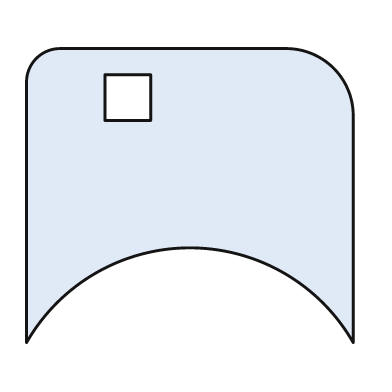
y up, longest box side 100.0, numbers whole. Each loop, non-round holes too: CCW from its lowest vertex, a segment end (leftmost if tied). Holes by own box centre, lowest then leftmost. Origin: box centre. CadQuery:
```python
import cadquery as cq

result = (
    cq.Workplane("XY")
    .moveTo(-50.0, -45.0)
    .threePointArc((0.0, -16.0), (50.0, -45.0))
    .lineTo(50.0, 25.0)
    .threePointArc((44.0, 39.0), (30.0, 45.0))
    .lineTo(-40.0, 45.0)
    .threePointArc((-47.0, 42.0), (-50.0, 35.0))
    .close()
    .moveTo(-26.0, 23.0)
    .lineTo(-12.0, 23.0)
    .lineTo(-12.0, 37.0)
    .lineTo(-26.0, 37.0)
    .close()
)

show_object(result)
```